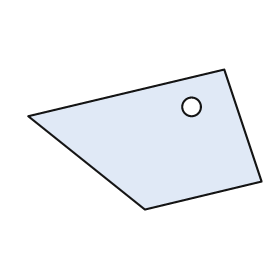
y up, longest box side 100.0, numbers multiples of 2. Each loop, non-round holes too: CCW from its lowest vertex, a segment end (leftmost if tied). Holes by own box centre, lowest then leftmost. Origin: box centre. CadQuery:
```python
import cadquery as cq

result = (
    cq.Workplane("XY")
    .moveTo(0.0, -30.0)
    .lineTo(50.0, -18.0)
    .lineTo(34.0, 30.0)
    .lineTo(-50.0, 10.0)
    .close()
    .moveTo(20.0, 14.0)
    .circle(4.0)
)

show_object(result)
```